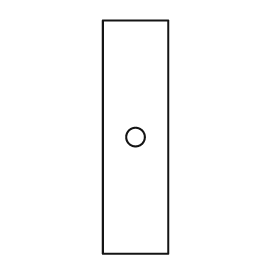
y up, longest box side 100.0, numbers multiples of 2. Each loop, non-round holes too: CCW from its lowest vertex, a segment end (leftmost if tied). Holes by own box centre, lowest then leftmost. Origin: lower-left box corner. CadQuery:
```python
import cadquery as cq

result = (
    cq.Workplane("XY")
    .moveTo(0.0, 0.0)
    .lineTo(28.0, 0.0)
    .lineTo(28.0, 100.0)
    .lineTo(0.0, 100.0)
    .close()
    .moveTo(14.0, 50.0)
    .circle(4.0)
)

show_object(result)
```